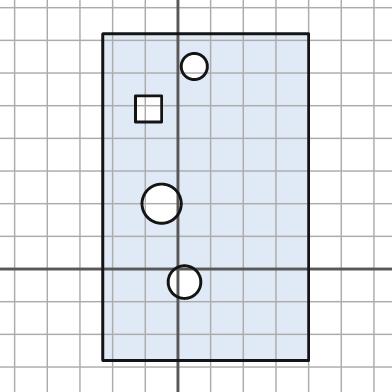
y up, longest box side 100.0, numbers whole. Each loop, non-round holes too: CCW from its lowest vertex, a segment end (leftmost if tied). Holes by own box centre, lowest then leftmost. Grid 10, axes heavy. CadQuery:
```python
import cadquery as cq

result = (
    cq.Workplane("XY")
    .moveTo(-23.0, -28.0)
    .lineTo(40.0, -28.0)
    .lineTo(40.0, 72.0)
    .lineTo(-23.0, 72.0)
    .close()
    .moveTo(2.0, -4.0)
    .circle(5.0)
    .moveTo(-5.0, 20.0)
    .circle(6.0)
    .moveTo(-13.0, 45.0)
    .lineTo(-5.0, 45.0)
    .lineTo(-5.0, 53.0)
    .lineTo(-13.0, 53.0)
    .close()
    .moveTo(5.0, 62.0)
    .circle(4.0)
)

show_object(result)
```